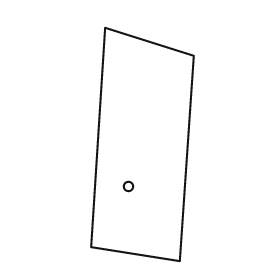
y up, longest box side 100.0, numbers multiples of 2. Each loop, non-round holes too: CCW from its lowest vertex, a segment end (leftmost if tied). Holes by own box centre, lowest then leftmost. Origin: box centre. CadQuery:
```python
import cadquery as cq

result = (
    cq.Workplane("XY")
    .moveTo(16.0, -50.0)
    .lineTo(22.0, 38.0)
    .lineTo(-16.0, 50.0)
    .lineTo(-22.0, -44.0)
    .close()
    .moveTo(-6.0, -18.0)
    .circle(2.0)
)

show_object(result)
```